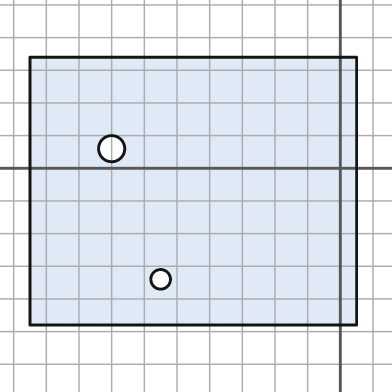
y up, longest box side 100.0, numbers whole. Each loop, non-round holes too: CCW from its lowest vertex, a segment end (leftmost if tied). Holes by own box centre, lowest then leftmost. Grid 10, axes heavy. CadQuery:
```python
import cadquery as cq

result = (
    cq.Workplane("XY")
    .moveTo(-95.0, -48.0)
    .lineTo(5.0, -48.0)
    .lineTo(5.0, 34.0)
    .lineTo(-95.0, 34.0)
    .close()
    .moveTo(-55.0, -34.0)
    .circle(3.0)
    .moveTo(-70.0, 6.0)
    .circle(4.0)
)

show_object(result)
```